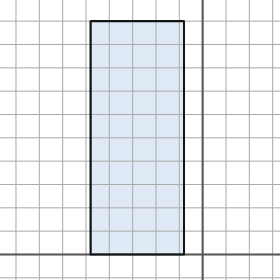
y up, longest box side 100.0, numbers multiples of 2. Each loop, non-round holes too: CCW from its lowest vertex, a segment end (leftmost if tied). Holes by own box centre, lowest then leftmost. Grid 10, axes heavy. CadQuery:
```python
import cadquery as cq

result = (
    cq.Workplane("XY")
    .moveTo(-48.0, 0.0)
    .lineTo(-8.0, 0.0)
    .lineTo(-8.0, 100.0)
    .lineTo(-48.0, 100.0)
    .close()
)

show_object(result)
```